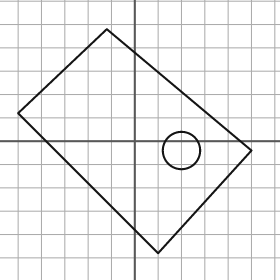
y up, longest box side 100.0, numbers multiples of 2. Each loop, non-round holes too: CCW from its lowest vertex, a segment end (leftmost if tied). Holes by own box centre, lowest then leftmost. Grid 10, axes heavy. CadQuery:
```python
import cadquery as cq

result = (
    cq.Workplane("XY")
    .moveTo(10.0, -48.0)
    .lineTo(50.0, -4.0)
    .lineTo(-12.0, 48.0)
    .lineTo(-50.0, 12.0)
    .close()
    .moveTo(20.0, -4.0)
    .circle(8.0)
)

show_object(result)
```